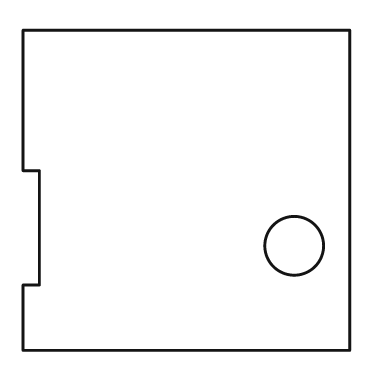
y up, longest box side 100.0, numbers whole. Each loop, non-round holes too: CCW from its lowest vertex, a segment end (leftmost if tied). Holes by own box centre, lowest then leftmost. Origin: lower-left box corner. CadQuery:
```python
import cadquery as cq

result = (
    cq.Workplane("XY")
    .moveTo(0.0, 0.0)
    .lineTo(100.0, 0.0)
    .lineTo(100.0, 98.0)
    .lineTo(0.0, 98.0)
    .lineTo(0.0, 55.0)
    .lineTo(5.0, 55.0)
    .lineTo(5.0, 20.0)
    .lineTo(0.0, 20.0)
    .close()
    .moveTo(83.0, 32.0)
    .circle(9.0)
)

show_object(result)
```